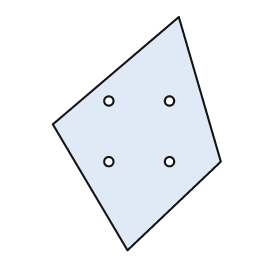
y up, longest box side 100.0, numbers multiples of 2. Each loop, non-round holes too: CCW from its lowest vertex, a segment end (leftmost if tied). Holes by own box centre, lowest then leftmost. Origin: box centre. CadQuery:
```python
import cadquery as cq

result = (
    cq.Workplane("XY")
    .moveTo(-4.0, -50.0)
    .lineTo(36.0, -12.0)
    .lineTo(18.0, 50.0)
    .lineTo(-36.0, 4.0)
    .close()
    .moveTo(-12.0, -12.0)
    .circle(2.0)
    .moveTo(14.0, -12.0)
    .circle(2.0)
    .moveTo(-12.0, 14.0)
    .circle(2.0)
    .moveTo(14.0, 14.0)
    .circle(2.0)
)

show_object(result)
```